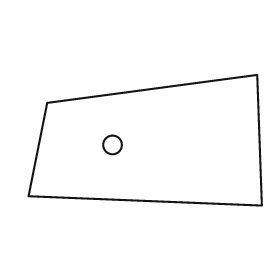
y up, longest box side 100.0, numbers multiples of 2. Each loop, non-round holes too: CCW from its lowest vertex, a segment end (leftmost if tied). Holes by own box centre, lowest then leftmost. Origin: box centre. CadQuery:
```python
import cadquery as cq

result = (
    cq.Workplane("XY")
    .moveTo(50.0, -28.0)
    .lineTo(48.0, 28.0)
    .lineTo(-42.0, 16.0)
    .lineTo(-50.0, -24.0)
    .close()
    .moveTo(-14.0, -2.0)
    .circle(4.0)
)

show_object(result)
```